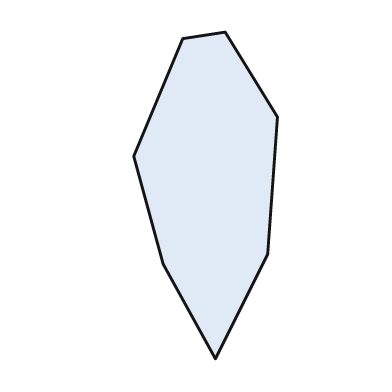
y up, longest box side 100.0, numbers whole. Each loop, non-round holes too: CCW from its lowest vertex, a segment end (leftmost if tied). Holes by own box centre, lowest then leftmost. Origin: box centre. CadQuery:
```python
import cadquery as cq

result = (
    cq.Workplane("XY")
    .moveTo(3.0, -50.0)
    .lineTo(19.0, -18.0)
    .lineTo(22.0, 24.0)
    .lineTo(6.0, 50.0)
    .lineTo(-7.0, 48.0)
    .lineTo(-22.0, 12.0)
    .lineTo(-13.0, -21.0)
    .close()
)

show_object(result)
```